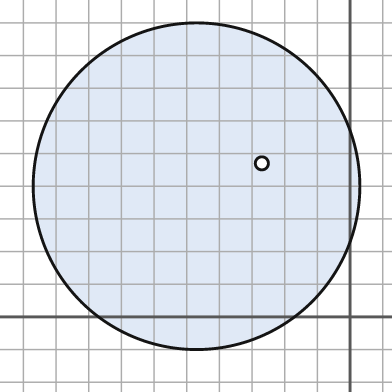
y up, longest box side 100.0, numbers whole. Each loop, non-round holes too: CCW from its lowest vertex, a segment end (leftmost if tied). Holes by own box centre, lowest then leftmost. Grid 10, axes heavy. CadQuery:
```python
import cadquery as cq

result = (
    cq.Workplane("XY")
    .moveTo(-47.0, 40.0)
    .circle(50.0)
    .moveTo(-27.0, 47.0)
    .circle(2.0)
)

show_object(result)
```